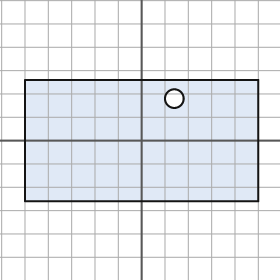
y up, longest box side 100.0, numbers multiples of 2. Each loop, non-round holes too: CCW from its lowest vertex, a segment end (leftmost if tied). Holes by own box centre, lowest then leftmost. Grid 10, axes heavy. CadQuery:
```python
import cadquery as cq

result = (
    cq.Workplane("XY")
    .moveTo(-50.0, -26.0)
    .lineTo(50.0, -26.0)
    .lineTo(50.0, 26.0)
    .lineTo(-50.0, 26.0)
    .close()
    .moveTo(14.0, 18.0)
    .circle(4.0)
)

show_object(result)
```